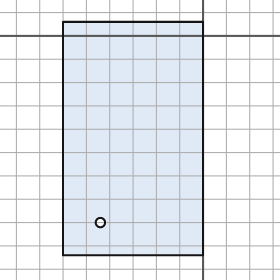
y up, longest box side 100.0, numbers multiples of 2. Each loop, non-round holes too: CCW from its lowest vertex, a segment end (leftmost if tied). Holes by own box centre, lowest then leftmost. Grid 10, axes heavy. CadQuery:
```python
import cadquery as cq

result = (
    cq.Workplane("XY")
    .moveTo(-60.0, -94.0)
    .lineTo(0.0, -94.0)
    .lineTo(0.0, 6.0)
    .lineTo(-60.0, 6.0)
    .close()
    .moveTo(-44.0, -80.0)
    .circle(2.0)
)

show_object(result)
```